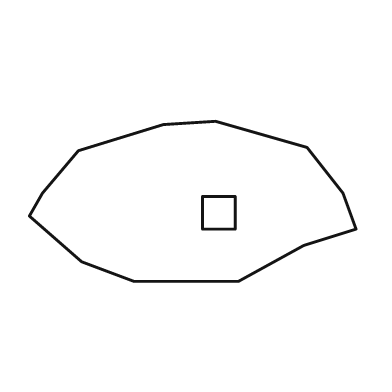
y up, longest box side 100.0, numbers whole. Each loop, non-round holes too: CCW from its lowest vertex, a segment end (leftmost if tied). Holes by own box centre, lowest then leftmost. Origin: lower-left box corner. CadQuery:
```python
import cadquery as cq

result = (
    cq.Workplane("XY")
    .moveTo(32.0, 0.0)
    .lineTo(64.0, 0.0)
    .lineTo(84.0, 11.0)
    .lineTo(100.0, 16.0)
    .lineTo(96.0, 27.0)
    .lineTo(85.0, 41.0)
    .lineTo(57.0, 49.0)
    .lineTo(41.0, 48.0)
    .lineTo(15.0, 40.0)
    .lineTo(4.0, 27.0)
    .lineTo(0.0, 20.0)
    .lineTo(16.0, 6.0)
    .close()
    .moveTo(53.0, 16.0)
    .lineTo(63.0, 16.0)
    .lineTo(63.0, 26.0)
    .lineTo(53.0, 26.0)
    .close()
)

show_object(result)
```